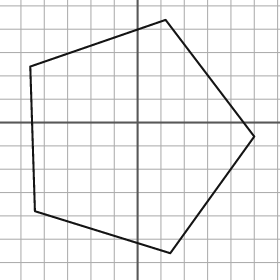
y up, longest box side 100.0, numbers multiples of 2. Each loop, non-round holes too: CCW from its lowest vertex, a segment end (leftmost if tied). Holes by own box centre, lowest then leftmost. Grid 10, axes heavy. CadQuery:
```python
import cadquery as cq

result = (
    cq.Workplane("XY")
    .moveTo(14.0, -56.0)
    .lineTo(50.0, -6.0)
    .lineTo(12.0, 44.0)
    .lineTo(-46.0, 24.0)
    .lineTo(-44.0, -38.0)
    .close()
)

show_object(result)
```